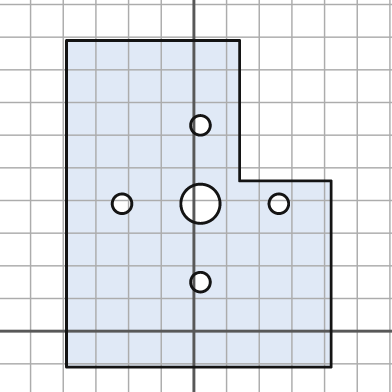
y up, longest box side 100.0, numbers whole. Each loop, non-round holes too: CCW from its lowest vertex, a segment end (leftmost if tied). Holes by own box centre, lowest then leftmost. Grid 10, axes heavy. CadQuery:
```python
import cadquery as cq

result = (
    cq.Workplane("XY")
    .moveTo(-39.0, -11.0)
    .lineTo(42.0, -11.0)
    .lineTo(42.0, 46.0)
    .lineTo(14.0, 46.0)
    .lineTo(14.0, 89.0)
    .lineTo(-39.0, 89.0)
    .close()
    .moveTo(2.0, 15.0)
    .circle(3.0)
    .moveTo(-22.0, 39.0)
    .circle(3.0)
    .moveTo(2.0, 39.0)
    .circle(6.0)
    .moveTo(26.0, 39.0)
    .circle(3.0)
    .moveTo(2.0, 63.0)
    .circle(3.0)
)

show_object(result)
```